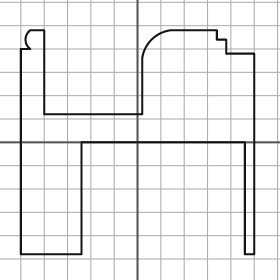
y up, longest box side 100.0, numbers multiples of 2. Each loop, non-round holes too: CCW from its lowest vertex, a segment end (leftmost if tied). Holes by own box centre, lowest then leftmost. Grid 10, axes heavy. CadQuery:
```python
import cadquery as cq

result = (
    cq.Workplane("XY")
    .moveTo(-50.0, -48.0)
    .lineTo(-24.0, -48.0)
    .lineTo(-24.0, 0.0)
    .lineTo(46.0, 0.0)
    .lineTo(46.0, -48.0)
    .lineTo(50.0, -48.0)
    .lineTo(50.0, 38.0)
    .lineTo(38.0, 38.0)
    .lineTo(38.0, 44.0)
    .lineTo(34.0, 44.0)
    .lineTo(34.0, 48.0)
    .lineTo(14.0, 48.0)
    .threePointArc((6.0, 44.0), (2.0, 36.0))
    .lineTo(2.0, 12.0)
    .lineTo(-40.0, 12.0)
    .lineTo(-40.0, 48.0)
    .lineTo(-46.0, 48.0)
    .threePointArc((-48.0, 44.0), (-46.0, 40.0))
    .lineTo(-50.0, 40.0)
    .close()
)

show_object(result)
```